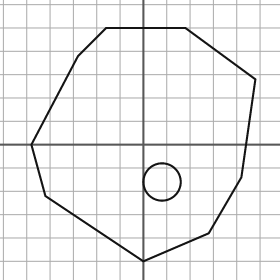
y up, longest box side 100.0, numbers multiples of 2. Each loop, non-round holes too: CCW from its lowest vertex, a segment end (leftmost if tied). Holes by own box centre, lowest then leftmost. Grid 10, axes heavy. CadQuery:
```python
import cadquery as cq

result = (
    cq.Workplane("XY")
    .moveTo(0.0, -50.0)
    .lineTo(28.0, -38.0)
    .lineTo(42.0, -14.0)
    .lineTo(48.0, 28.0)
    .lineTo(18.0, 50.0)
    .lineTo(-16.0, 50.0)
    .lineTo(-28.0, 38.0)
    .lineTo(-48.0, 0.0)
    .lineTo(-42.0, -22.0)
    .close()
    .moveTo(8.0, -16.0)
    .circle(8.0)
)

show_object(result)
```